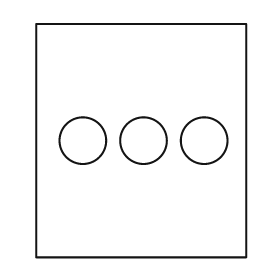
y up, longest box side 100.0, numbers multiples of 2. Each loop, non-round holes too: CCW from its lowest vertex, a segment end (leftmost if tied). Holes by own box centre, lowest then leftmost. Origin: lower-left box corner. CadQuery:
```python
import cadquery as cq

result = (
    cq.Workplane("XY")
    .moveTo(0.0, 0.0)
    .lineTo(90.0, 0.0)
    .lineTo(90.0, 100.0)
    .lineTo(0.0, 100.0)
    .close()
    .moveTo(20.0, 50.0)
    .circle(10.0)
    .moveTo(46.0, 50.0)
    .circle(10.0)
    .moveTo(72.0, 50.0)
    .circle(10.0)
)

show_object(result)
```